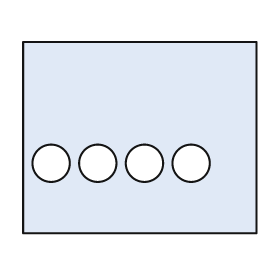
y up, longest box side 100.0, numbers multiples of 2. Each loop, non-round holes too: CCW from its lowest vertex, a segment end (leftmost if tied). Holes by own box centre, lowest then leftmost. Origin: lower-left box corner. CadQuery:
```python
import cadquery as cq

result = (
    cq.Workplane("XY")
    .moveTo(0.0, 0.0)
    .lineTo(100.0, 0.0)
    .lineTo(100.0, 82.0)
    .lineTo(0.0, 82.0)
    .close()
    .moveTo(12.0, 30.0)
    .circle(8.0)
    .moveTo(32.0, 30.0)
    .circle(8.0)
    .moveTo(52.0, 30.0)
    .circle(8.0)
    .moveTo(72.0, 30.0)
    .circle(8.0)
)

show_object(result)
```